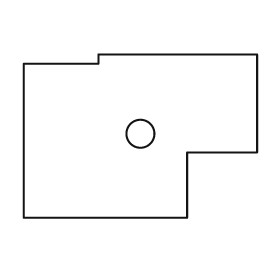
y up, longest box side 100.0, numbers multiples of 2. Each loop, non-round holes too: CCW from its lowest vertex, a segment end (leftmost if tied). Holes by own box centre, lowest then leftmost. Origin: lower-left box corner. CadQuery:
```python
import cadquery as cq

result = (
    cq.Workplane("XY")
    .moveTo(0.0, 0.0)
    .lineTo(70.0, 0.0)
    .lineTo(70.0, 28.0)
    .lineTo(100.0, 28.0)
    .lineTo(100.0, 70.0)
    .lineTo(32.0, 70.0)
    .lineTo(32.0, 66.0)
    .lineTo(0.0, 66.0)
    .close()
    .moveTo(50.0, 36.0)
    .circle(6.0)
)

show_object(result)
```